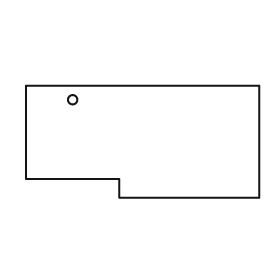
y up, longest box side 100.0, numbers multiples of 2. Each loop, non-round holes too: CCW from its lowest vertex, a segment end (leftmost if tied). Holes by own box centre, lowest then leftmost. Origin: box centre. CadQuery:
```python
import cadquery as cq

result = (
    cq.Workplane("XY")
    .moveTo(-10.0, -24.0)
    .lineTo(50.0, -24.0)
    .lineTo(50.0, 24.0)
    .lineTo(-50.0, 24.0)
    .lineTo(-50.0, -16.0)
    .lineTo(-10.0, -16.0)
    .close()
    .moveTo(-30.0, 18.0)
    .circle(2.0)
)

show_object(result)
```